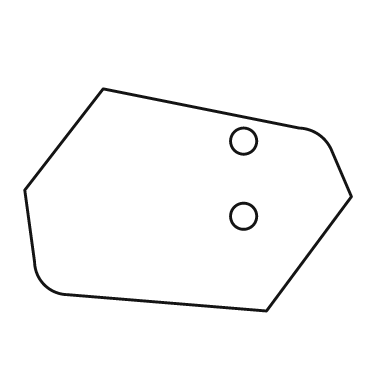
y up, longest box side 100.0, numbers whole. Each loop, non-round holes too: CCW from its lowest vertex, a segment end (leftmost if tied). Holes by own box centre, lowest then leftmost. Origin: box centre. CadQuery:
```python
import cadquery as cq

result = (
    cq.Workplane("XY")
    .moveTo(24.0, -34.0)
    .lineTo(50.0, 1.0)
    .lineTo(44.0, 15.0)
    .threePointArc((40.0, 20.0), (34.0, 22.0))
    .lineTo(-26.0, 34.0)
    .lineTo(-50.0, 3.0)
    .lineTo(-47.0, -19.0)
    .threePointArc((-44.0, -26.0), (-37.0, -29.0))
    .close()
    .moveTo(17.0, -5.0)
    .circle(4.0)
    .moveTo(17.0, 18.0)
    .circle(4.0)
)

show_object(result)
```